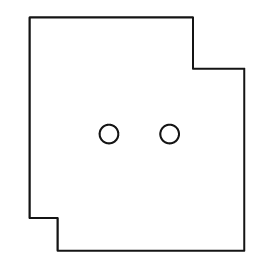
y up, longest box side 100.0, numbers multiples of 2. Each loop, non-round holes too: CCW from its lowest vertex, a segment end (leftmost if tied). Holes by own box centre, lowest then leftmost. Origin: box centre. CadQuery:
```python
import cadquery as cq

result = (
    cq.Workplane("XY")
    .moveTo(-34.0, -50.0)
    .lineTo(46.0, -50.0)
    .lineTo(46.0, 28.0)
    .lineTo(24.0, 28.0)
    .lineTo(24.0, 50.0)
    .lineTo(-46.0, 50.0)
    .lineTo(-46.0, -36.0)
    .lineTo(-34.0, -36.0)
    .close()
    .moveTo(-12.0, 0.0)
    .circle(4.0)
    .moveTo(14.0, 0.0)
    .circle(4.0)
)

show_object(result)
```